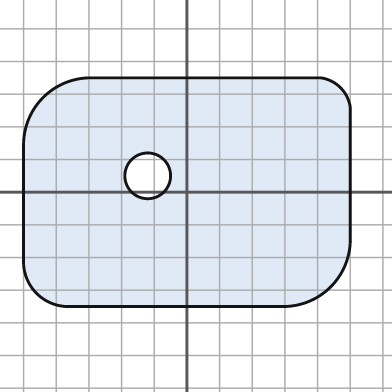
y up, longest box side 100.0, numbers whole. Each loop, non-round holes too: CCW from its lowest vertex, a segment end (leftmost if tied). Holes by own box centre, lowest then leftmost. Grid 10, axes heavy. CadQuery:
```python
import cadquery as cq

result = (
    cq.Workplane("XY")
    .moveTo(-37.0, -35.0)
    .lineTo(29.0, -35.0)
    .threePointArc((44.0, -29.0), (50.0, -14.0))
    .lineTo(50.0, 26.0)
    .threePointArc((47.0, 32.0), (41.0, 35.0))
    .lineTo(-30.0, 35.0)
    .threePointArc((-44.0, 29.0), (-50.0, 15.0))
    .lineTo(-50.0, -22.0)
    .threePointArc((-46.0, -31.0), (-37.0, -35.0))
    .close()
    .moveTo(-12.0, 5.0)
    .circle(7.0)
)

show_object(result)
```